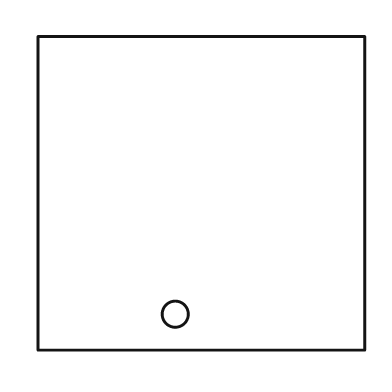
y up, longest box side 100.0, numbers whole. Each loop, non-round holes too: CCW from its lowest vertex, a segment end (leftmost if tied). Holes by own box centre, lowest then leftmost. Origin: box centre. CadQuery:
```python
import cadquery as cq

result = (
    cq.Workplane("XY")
    .moveTo(-50.0, -48.0)
    .lineTo(50.0, -48.0)
    .lineTo(50.0, 48.0)
    .lineTo(-50.0, 48.0)
    .close()
    .moveTo(-8.0, -37.0)
    .circle(4.0)
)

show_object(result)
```